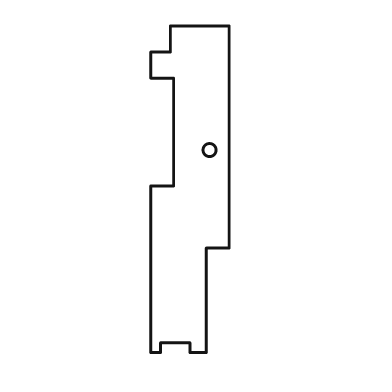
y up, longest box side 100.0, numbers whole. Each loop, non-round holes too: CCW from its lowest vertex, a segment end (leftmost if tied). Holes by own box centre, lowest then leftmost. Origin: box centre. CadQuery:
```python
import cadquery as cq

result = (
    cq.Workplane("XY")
    .moveTo(-12.0, -50.0)
    .lineTo(-9.0, -50.0)
    .lineTo(-9.0, -47.0)
    .lineTo(0.0, -47.0)
    .lineTo(0.0, -50.0)
    .lineTo(5.0, -50.0)
    .lineTo(5.0, -18.0)
    .lineTo(12.0, -18.0)
    .lineTo(12.0, 50.0)
    .lineTo(-6.0, 50.0)
    .lineTo(-6.0, 42.0)
    .lineTo(-12.0, 42.0)
    .lineTo(-12.0, 34.0)
    .lineTo(-5.0, 34.0)
    .lineTo(-5.0, 1.0)
    .lineTo(-12.0, 1.0)
    .close()
    .moveTo(6.0, 12.0)
    .circle(2.0)
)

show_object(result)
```